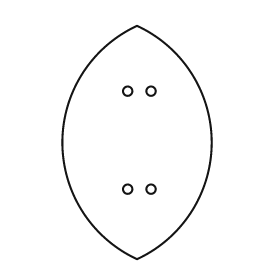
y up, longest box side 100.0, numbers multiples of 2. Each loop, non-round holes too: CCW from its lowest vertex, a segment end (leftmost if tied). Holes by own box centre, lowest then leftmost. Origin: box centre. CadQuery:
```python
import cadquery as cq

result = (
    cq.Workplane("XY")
    .moveTo(0.0, -50.0)
    .threePointArc((32.0, 0.0), (0.0, 50.0))
    .threePointArc((-32.0, 0.0), (0.0, -50.0))
    .close()
    .moveTo(-4.0, -20.0)
    .circle(2.0)
    .moveTo(6.0, -20.0)
    .circle(2.0)
    .moveTo(-4.0, 22.0)
    .circle(2.0)
    .moveTo(6.0, 22.0)
    .circle(2.0)
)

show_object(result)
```